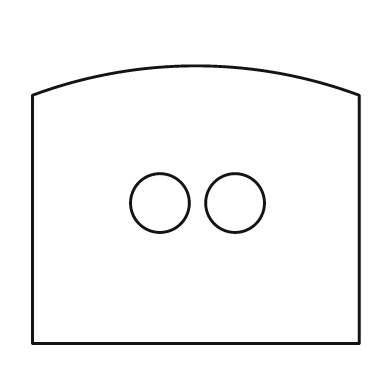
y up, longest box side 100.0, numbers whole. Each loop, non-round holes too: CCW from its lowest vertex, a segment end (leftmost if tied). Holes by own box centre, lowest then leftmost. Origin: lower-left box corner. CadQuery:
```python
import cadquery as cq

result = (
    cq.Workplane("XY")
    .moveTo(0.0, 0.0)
    .lineTo(100.0, 0.0)
    .lineTo(100.0, 76.0)
    .threePointArc((50.0, 85.0), (0.0, 76.0))
    .close()
    .moveTo(39.0, 43.0)
    .circle(9.0)
    .moveTo(62.0, 43.0)
    .circle(9.0)
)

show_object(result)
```